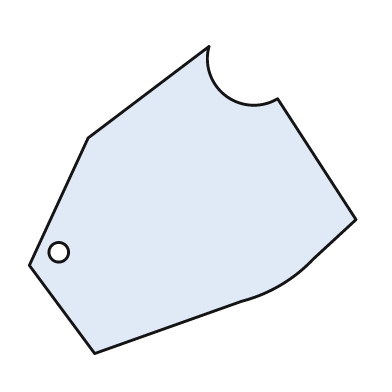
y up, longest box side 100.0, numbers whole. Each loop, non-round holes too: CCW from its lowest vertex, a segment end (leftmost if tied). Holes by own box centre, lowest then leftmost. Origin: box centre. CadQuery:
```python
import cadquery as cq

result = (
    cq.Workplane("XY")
    .moveTo(-30.0, -47.0)
    .lineTo(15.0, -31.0)
    .threePointArc((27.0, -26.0), (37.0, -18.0))
    .lineTo(50.0, -6.0)
    .lineTo(26.0, 31.0)
    .threePointArc((10.0, 32.0), (5.0, 47.0))
    .lineTo(-32.0, 19.0)
    .lineTo(-50.0, -20.0)
    .close()
    .moveTo(-41.0, -16.0)
    .circle(3.0)
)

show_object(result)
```